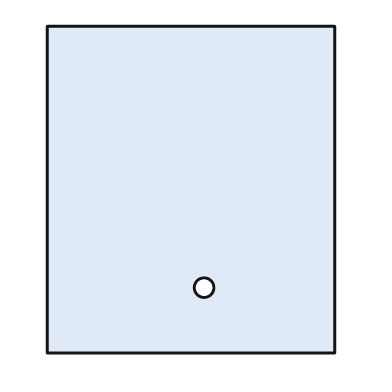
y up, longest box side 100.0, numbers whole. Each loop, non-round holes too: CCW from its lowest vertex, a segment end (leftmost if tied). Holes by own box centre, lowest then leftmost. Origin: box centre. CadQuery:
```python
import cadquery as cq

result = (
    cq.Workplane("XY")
    .moveTo(-44.0, -50.0)
    .lineTo(44.0, -50.0)
    .lineTo(44.0, 50.0)
    .lineTo(-44.0, 50.0)
    .close()
    .moveTo(4.0, -30.0)
    .circle(3.0)
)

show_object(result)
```